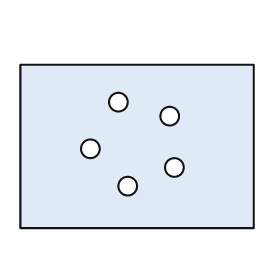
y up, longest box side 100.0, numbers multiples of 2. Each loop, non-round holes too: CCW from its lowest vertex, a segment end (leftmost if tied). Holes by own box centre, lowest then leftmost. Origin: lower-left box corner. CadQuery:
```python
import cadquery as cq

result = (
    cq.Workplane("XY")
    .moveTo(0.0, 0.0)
    .lineTo(100.0, 0.0)
    .lineTo(100.0, 70.0)
    .lineTo(0.0, 70.0)
    .close()
    .moveTo(46.0, 18.0)
    .circle(4.0)
    .moveTo(66.0, 26.0)
    .circle(4.0)
    .moveTo(30.0, 34.0)
    .circle(4.0)
    .moveTo(64.0, 48.0)
    .circle(4.0)
    .moveTo(42.0, 54.0)
    .circle(4.0)
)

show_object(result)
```